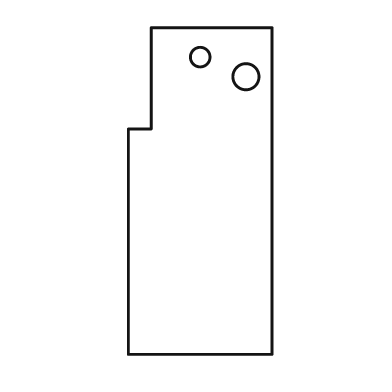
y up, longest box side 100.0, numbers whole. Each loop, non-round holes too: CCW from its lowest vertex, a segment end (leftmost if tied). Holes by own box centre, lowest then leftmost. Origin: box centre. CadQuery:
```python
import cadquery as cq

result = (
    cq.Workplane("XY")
    .moveTo(-22.0, -50.0)
    .lineTo(22.0, -50.0)
    .lineTo(22.0, 50.0)
    .lineTo(-15.0, 50.0)
    .lineTo(-15.0, 19.0)
    .lineTo(-22.0, 19.0)
    .close()
    .moveTo(14.0, 35.0)
    .circle(4.0)
    .moveTo(0.0, 41.0)
    .circle(3.0)
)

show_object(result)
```